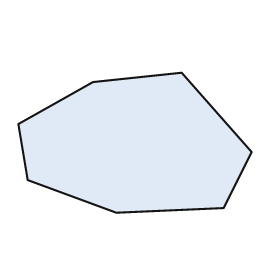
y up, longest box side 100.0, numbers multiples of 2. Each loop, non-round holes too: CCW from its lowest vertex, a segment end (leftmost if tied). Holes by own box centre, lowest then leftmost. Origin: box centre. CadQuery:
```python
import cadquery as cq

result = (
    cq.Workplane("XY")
    .moveTo(-8.0, -30.0)
    .lineTo(38.0, -28.0)
    .lineTo(50.0, -4.0)
    .lineTo(20.0, 30.0)
    .lineTo(-18.0, 26.0)
    .lineTo(-50.0, 8.0)
    .lineTo(-46.0, -16.0)
    .close()
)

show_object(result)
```